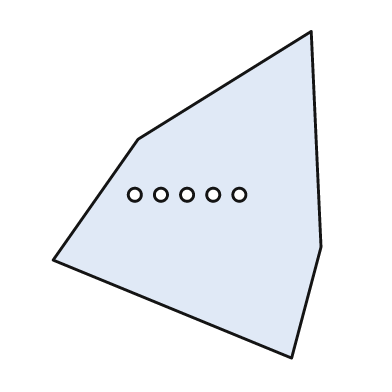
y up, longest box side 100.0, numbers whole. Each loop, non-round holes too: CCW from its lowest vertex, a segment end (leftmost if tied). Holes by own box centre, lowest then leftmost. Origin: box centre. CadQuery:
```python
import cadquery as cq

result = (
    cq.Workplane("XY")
    .moveTo(32.0, -50.0)
    .lineTo(41.0, -16.0)
    .lineTo(38.0, 50.0)
    .lineTo(-15.0, 17.0)
    .lineTo(-41.0, -20.0)
    .close()
    .moveTo(-16.0, 0.0)
    .circle(2.0)
    .moveTo(-8.0, 0.0)
    .circle(2.0)
    .moveTo(0.0, 0.0)
    .circle(2.0)
    .moveTo(8.0, 0.0)
    .circle(2.0)
    .moveTo(16.0, 0.0)
    .circle(2.0)
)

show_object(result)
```